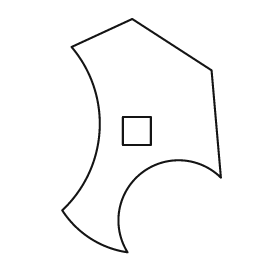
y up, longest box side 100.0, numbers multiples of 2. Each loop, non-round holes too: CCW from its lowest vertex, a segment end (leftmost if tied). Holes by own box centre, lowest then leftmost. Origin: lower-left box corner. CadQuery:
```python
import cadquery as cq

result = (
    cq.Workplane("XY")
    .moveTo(28.0, 0.0)
    .threePointArc((34.0, 34.0), (68.0, 32.0))
    .lineTo(64.0, 78.0)
    .lineTo(30.0, 100.0)
    .lineTo(4.0, 88.0)
    .threePointArc((16.0, 52.0), (0.0, 18.0))
    .threePointArc((12.0, 6.0), (28.0, 0.0))
    .close()
    .moveTo(26.0, 46.0)
    .lineTo(38.0, 46.0)
    .lineTo(38.0, 58.0)
    .lineTo(26.0, 58.0)
    .close()
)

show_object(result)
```